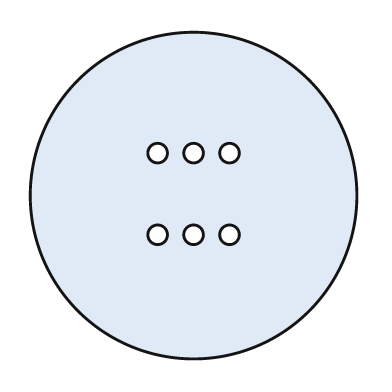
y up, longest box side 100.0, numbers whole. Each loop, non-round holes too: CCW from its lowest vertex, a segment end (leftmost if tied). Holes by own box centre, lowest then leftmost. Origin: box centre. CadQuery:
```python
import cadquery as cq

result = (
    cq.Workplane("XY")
    .moveTo(0.0, 0.0)
    .circle(50.0)
    .moveTo(-11.0, -12.0)
    .circle(3.0)
    .moveTo(0.0, -12.0)
    .circle(3.0)
    .moveTo(11.0, -12.0)
    .circle(3.0)
    .moveTo(-11.0, 13.0)
    .circle(3.0)
    .moveTo(0.0, 13.0)
    .circle(3.0)
    .moveTo(11.0, 13.0)
    .circle(3.0)
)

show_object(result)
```